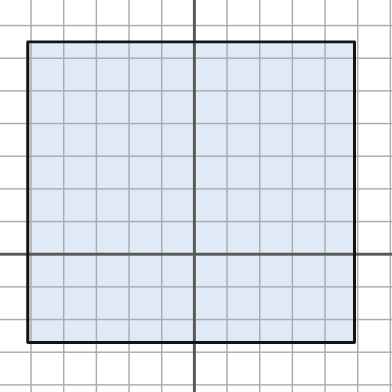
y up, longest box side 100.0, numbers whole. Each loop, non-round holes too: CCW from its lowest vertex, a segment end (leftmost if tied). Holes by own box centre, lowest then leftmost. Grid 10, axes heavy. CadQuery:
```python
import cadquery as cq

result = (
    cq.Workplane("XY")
    .moveTo(-51.0, -27.0)
    .lineTo(49.0, -27.0)
    .lineTo(49.0, 65.0)
    .lineTo(-51.0, 65.0)
    .close()
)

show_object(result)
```